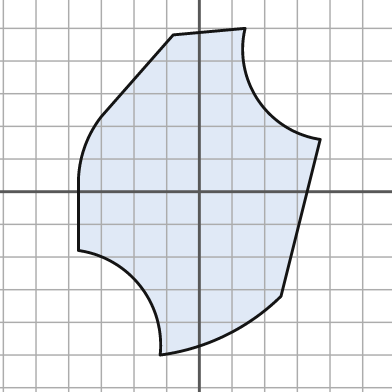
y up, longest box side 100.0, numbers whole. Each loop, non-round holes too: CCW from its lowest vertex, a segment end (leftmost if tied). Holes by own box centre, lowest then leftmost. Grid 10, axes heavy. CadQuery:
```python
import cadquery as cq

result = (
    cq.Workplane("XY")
    .moveTo(-12.0, -50.0)
    .threePointArc((8.0, -44.0), (25.0, -32.0))
    .lineTo(37.0, 16.0)
    .threePointArc((18.0, 28.0), (14.0, 50.0))
    .lineTo(-8.0, 48.0)
    .lineTo(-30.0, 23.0)
    .threePointArc((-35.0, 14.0), (-37.0, 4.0))
    .lineTo(-37.0, -18.0)
    .threePointArc((-18.0, -29.0), (-12.0, -50.0))
    .close()
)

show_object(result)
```